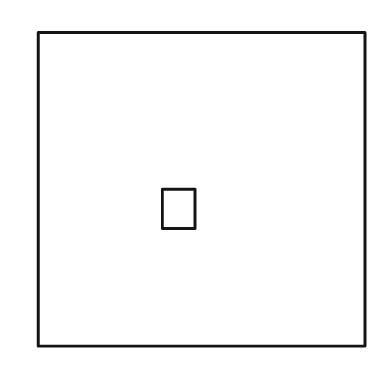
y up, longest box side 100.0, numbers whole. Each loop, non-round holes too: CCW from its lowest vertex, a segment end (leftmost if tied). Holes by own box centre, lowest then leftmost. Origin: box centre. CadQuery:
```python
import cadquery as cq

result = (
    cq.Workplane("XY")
    .moveTo(-50.0, -48.0)
    .lineTo(50.0, -48.0)
    .lineTo(50.0, 48.0)
    .lineTo(-50.0, 48.0)
    .close()
    .moveTo(-12.0, -12.0)
    .lineTo(-2.0, -12.0)
    .lineTo(-2.0, 0.0)
    .lineTo(-12.0, 0.0)
    .close()
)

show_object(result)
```